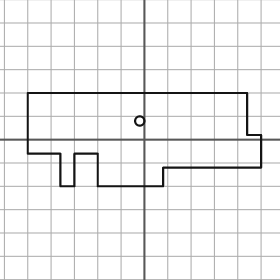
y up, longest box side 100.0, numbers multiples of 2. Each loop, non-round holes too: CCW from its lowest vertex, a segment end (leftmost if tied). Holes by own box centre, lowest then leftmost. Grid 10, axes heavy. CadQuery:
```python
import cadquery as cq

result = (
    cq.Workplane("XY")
    .moveTo(-36.0, -20.0)
    .lineTo(-30.0, -20.0)
    .lineTo(-30.0, -6.0)
    .lineTo(-20.0, -6.0)
    .lineTo(-20.0, -20.0)
    .lineTo(8.0, -20.0)
    .lineTo(8.0, -12.0)
    .lineTo(50.0, -12.0)
    .lineTo(50.0, 2.0)
    .lineTo(44.0, 2.0)
    .lineTo(44.0, 20.0)
    .lineTo(-50.0, 20.0)
    .lineTo(-50.0, -6.0)
    .lineTo(-36.0, -6.0)
    .close()
    .moveTo(-2.0, 8.0)
    .circle(2.0)
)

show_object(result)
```